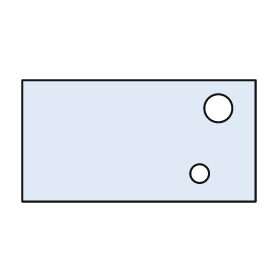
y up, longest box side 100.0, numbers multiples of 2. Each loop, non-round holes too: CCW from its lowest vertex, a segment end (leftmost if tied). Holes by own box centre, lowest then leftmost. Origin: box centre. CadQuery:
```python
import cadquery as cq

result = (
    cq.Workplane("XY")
    .moveTo(-50.0, -26.0)
    .lineTo(50.0, -26.0)
    .lineTo(50.0, 26.0)
    .lineTo(-50.0, 26.0)
    .close()
    .moveTo(26.0, -14.0)
    .circle(4.0)
    .moveTo(34.0, 14.0)
    .circle(6.0)
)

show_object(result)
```